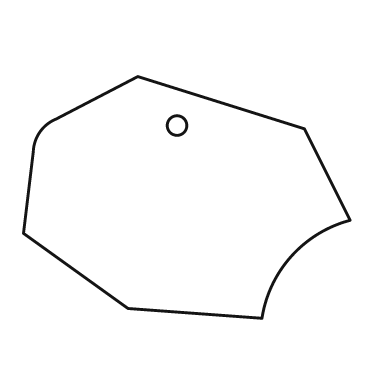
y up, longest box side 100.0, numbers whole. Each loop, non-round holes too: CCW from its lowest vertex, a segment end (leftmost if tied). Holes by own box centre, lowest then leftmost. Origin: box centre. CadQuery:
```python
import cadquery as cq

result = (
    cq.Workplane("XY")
    .moveTo(23.0, -37.0)
    .threePointArc((32.0, -18.0), (50.0, -7.0))
    .lineTo(36.0, 21.0)
    .lineTo(-15.0, 37.0)
    .lineTo(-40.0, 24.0)
    .threePointArc((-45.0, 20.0), (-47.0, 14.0))
    .lineTo(-50.0, -11.0)
    .lineTo(-18.0, -34.0)
    .close()
    .moveTo(-3.0, 22.0)
    .circle(3.0)
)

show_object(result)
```